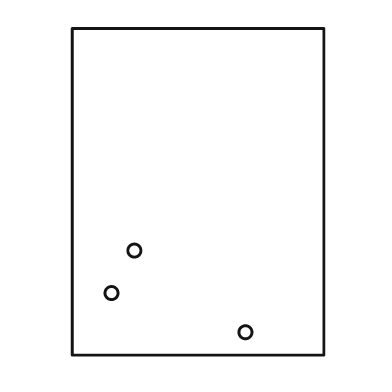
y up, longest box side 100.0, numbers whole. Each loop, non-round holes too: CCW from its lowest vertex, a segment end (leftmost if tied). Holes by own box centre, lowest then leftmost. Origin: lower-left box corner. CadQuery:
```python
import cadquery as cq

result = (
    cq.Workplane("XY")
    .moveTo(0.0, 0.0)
    .lineTo(77.0, 0.0)
    .lineTo(77.0, 100.0)
    .lineTo(0.0, 100.0)
    .close()
    .moveTo(53.0, 7.0)
    .circle(2.0)
    .moveTo(12.0, 19.0)
    .circle(2.0)
    .moveTo(19.0, 32.0)
    .circle(2.0)
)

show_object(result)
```